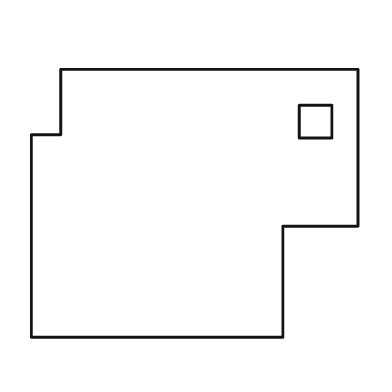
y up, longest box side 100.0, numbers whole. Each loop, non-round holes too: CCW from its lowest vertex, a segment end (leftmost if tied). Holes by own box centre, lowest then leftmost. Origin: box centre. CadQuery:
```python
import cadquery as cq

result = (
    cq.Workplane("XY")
    .moveTo(-50.0, -41.0)
    .lineTo(27.0, -41.0)
    .lineTo(27.0, -7.0)
    .lineTo(50.0, -7.0)
    .lineTo(50.0, 41.0)
    .lineTo(-41.0, 41.0)
    .lineTo(-41.0, 21.0)
    .lineTo(-50.0, 21.0)
    .close()
    .moveTo(32.0, 20.0)
    .lineTo(42.0, 20.0)
    .lineTo(42.0, 30.0)
    .lineTo(32.0, 30.0)
    .close()
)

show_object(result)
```